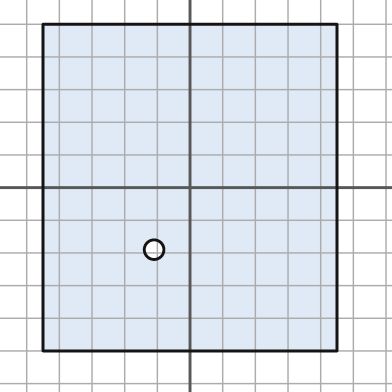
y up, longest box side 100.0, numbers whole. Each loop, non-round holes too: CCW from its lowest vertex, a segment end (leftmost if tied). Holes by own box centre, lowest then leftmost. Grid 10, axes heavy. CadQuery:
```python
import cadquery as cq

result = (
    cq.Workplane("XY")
    .moveTo(-45.0, -50.0)
    .lineTo(45.0, -50.0)
    .lineTo(45.0, 50.0)
    .lineTo(-45.0, 50.0)
    .close()
    .moveTo(-11.0, -19.0)
    .circle(3.0)
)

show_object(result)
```